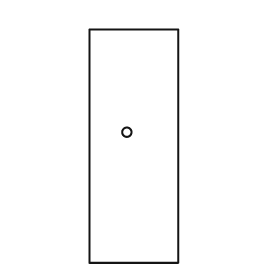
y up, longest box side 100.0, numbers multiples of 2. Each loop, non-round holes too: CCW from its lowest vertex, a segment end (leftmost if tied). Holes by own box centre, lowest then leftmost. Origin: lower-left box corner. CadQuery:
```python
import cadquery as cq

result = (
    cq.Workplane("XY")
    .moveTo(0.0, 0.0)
    .lineTo(38.0, 0.0)
    .lineTo(38.0, 100.0)
    .lineTo(0.0, 100.0)
    .close()
    .moveTo(16.0, 56.0)
    .circle(2.0)
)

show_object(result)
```